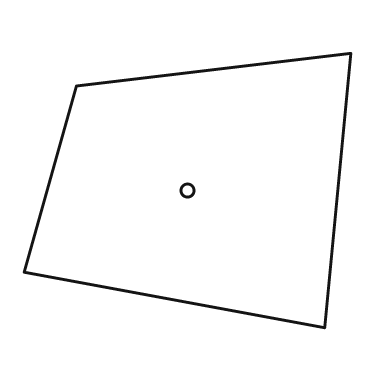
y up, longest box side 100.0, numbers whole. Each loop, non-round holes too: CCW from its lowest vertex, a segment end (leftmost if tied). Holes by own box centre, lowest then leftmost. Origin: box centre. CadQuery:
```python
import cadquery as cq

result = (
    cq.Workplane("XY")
    .moveTo(42.0, -42.0)
    .lineTo(50.0, 42.0)
    .lineTo(-34.0, 32.0)
    .lineTo(-50.0, -25.0)
    .close()
    .moveTo(0.0, 0.0)
    .circle(2.0)
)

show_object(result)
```